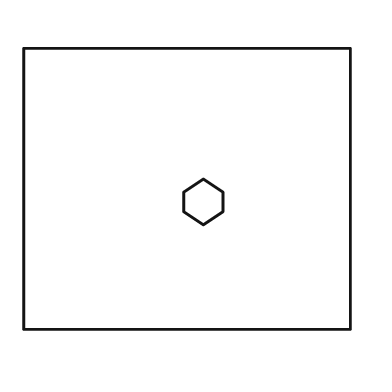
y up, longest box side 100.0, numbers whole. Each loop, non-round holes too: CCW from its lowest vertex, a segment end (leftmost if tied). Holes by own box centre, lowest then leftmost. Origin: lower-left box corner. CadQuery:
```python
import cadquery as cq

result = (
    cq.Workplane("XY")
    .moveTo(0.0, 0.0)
    .lineTo(100.0, 0.0)
    .lineTo(100.0, 86.0)
    .lineTo(0.0, 86.0)
    .close()
    .moveTo(55.0, 32.0)
    .lineTo(61.0, 36.0)
    .lineTo(61.0, 42.0)
    .lineTo(55.0, 46.0)
    .lineTo(49.0, 42.0)
    .lineTo(49.0, 36.0)
    .close()
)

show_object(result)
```